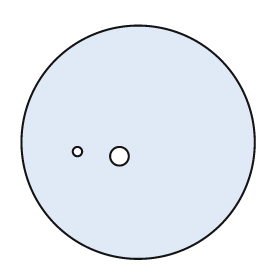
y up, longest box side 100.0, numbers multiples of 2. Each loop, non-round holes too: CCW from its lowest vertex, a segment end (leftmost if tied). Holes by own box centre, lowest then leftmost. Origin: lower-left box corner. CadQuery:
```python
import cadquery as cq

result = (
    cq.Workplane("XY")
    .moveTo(50.0, 50.0)
    .circle(50.0)
    .moveTo(42.0, 44.0)
    .circle(4.0)
    .moveTo(24.0, 46.0)
    .circle(2.0)
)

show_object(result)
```